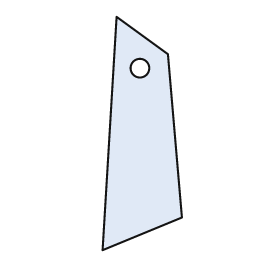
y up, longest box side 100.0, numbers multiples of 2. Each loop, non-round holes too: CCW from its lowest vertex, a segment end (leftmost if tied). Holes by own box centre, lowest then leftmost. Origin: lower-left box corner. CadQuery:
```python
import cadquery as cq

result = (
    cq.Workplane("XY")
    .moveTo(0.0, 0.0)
    .lineTo(34.0, 14.0)
    .lineTo(28.0, 84.0)
    .lineTo(6.0, 100.0)
    .close()
    .moveTo(16.0, 78.0)
    .circle(4.0)
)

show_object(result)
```